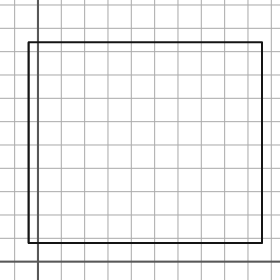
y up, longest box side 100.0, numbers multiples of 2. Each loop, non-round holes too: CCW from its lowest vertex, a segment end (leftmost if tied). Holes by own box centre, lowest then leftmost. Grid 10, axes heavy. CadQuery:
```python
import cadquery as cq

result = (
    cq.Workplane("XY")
    .moveTo(-4.0, 8.0)
    .lineTo(96.0, 8.0)
    .lineTo(96.0, 94.0)
    .lineTo(-4.0, 94.0)
    .close()
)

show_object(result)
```